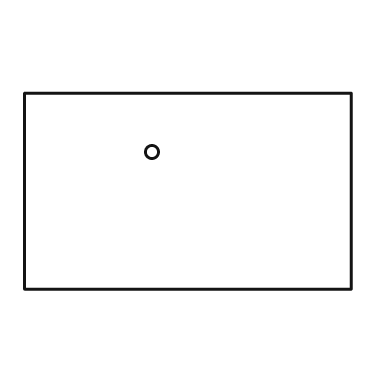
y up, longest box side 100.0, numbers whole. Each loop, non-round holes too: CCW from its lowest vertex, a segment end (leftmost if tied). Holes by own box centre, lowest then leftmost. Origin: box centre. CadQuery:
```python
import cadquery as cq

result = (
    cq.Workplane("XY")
    .moveTo(-50.0, -30.0)
    .lineTo(50.0, -30.0)
    .lineTo(50.0, 30.0)
    .lineTo(-50.0, 30.0)
    .close()
    .moveTo(-11.0, 12.0)
    .circle(2.0)
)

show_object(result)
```